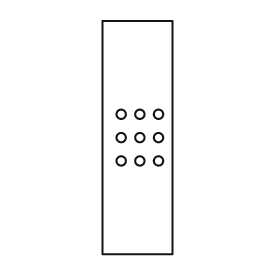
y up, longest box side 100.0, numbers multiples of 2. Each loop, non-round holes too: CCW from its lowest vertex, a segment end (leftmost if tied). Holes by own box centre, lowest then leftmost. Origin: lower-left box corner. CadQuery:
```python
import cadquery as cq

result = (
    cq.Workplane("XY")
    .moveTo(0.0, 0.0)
    .lineTo(30.0, 0.0)
    .lineTo(30.0, 100.0)
    .lineTo(0.0, 100.0)
    .close()
    .moveTo(8.0, 40.0)
    .circle(2.0)
    .moveTo(16.0, 40.0)
    .circle(2.0)
    .moveTo(24.0, 40.0)
    .circle(2.0)
    .moveTo(8.0, 50.0)
    .circle(2.0)
    .moveTo(16.0, 50.0)
    .circle(2.0)
    .moveTo(24.0, 50.0)
    .circle(2.0)
    .moveTo(8.0, 60.0)
    .circle(2.0)
    .moveTo(16.0, 60.0)
    .circle(2.0)
    .moveTo(24.0, 60.0)
    .circle(2.0)
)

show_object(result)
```